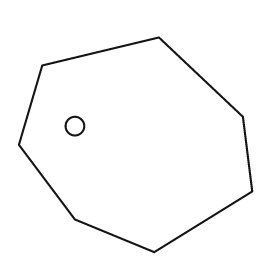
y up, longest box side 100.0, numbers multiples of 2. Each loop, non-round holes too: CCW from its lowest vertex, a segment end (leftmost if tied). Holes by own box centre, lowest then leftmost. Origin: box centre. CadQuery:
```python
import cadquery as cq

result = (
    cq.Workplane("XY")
    .moveTo(8.0, -46.0)
    .lineTo(50.0, -20.0)
    .lineTo(46.0, 12.0)
    .lineTo(10.0, 46.0)
    .lineTo(-40.0, 34.0)
    .lineTo(-50.0, 0.0)
    .lineTo(-26.0, -32.0)
    .close()
    .moveTo(-26.0, 8.0)
    .circle(4.0)
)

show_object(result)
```